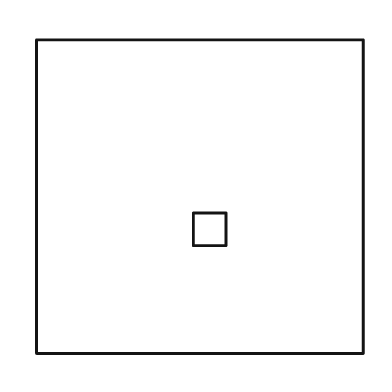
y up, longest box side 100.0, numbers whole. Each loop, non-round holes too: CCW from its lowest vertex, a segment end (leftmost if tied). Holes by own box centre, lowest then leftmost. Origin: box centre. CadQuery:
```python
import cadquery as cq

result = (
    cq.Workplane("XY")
    .moveTo(-50.0, -48.0)
    .lineTo(50.0, -48.0)
    .lineTo(50.0, 48.0)
    .lineTo(-50.0, 48.0)
    .close()
    .moveTo(-2.0, -15.0)
    .lineTo(8.0, -15.0)
    .lineTo(8.0, -5.0)
    .lineTo(-2.0, -5.0)
    .close()
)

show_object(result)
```